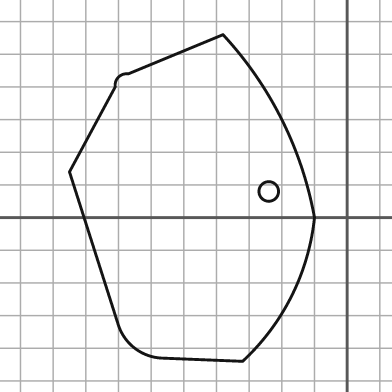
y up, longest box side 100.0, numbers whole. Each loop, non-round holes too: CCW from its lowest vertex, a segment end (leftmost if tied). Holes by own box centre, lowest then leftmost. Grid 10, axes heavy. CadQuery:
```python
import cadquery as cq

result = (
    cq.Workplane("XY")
    .moveTo(-32.0, -44.0)
    .threePointArc((-17.0, -24.0), (-10.0, 0.0))
    .threePointArc((-20.0, 30.0), (-38.0, 56.0))
    .lineTo(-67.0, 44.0)
    .threePointArc((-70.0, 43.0), (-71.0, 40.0))
    .lineTo(-85.0, 14.0)
    .lineTo(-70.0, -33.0)
    .threePointArc((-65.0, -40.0), (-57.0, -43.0))
    .close()
    .moveTo(-24.0, 8.0)
    .circle(3.0)
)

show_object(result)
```